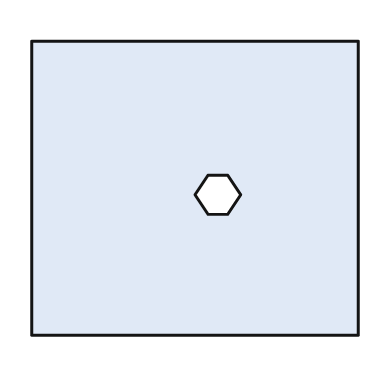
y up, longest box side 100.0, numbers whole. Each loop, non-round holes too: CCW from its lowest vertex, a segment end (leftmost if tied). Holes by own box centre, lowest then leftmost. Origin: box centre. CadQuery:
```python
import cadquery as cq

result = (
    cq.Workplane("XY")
    .moveTo(-50.0, -45.0)
    .lineTo(50.0, -45.0)
    .lineTo(50.0, 45.0)
    .lineTo(-50.0, 45.0)
    .close()
    .moveTo(4.0, -8.0)
    .lineTo(10.0, -8.0)
    .lineTo(14.0, -2.0)
    .lineTo(10.0, 4.0)
    .lineTo(4.0, 4.0)
    .lineTo(0.0, -2.0)
    .close()
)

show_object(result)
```